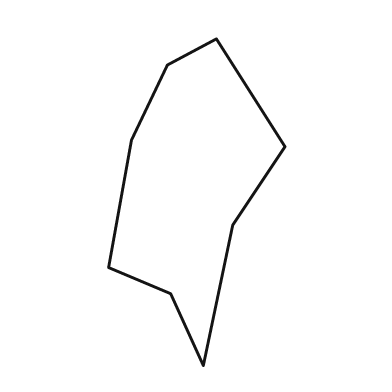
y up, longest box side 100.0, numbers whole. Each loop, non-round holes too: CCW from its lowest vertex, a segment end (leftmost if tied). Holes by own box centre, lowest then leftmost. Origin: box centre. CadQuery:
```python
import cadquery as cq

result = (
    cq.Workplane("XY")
    .moveTo(2.0, -50.0)
    .lineTo(11.0, -7.0)
    .lineTo(27.0, 17.0)
    .lineTo(6.0, 50.0)
    .lineTo(-9.0, 42.0)
    .lineTo(-20.0, 19.0)
    .lineTo(-27.0, -20.0)
    .lineTo(-8.0, -28.0)
    .close()
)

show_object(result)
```